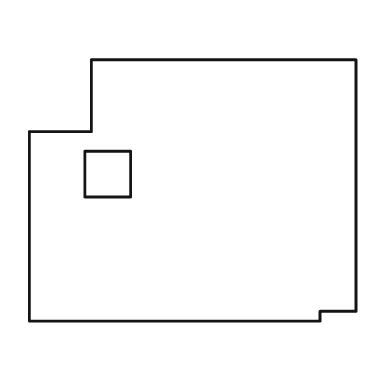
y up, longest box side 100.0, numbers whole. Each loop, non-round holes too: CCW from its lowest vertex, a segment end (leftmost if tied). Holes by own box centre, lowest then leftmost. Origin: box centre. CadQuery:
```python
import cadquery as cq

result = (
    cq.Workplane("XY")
    .moveTo(-50.0, -40.0)
    .lineTo(39.0, -40.0)
    .lineTo(39.0, -37.0)
    .lineTo(50.0, -37.0)
    .lineTo(50.0, 40.0)
    .lineTo(-31.0, 40.0)
    .lineTo(-31.0, 18.0)
    .lineTo(-50.0, 18.0)
    .close()
    .moveTo(-33.0, -2.0)
    .lineTo(-19.0, -2.0)
    .lineTo(-19.0, 12.0)
    .lineTo(-33.0, 12.0)
    .close()
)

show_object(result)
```